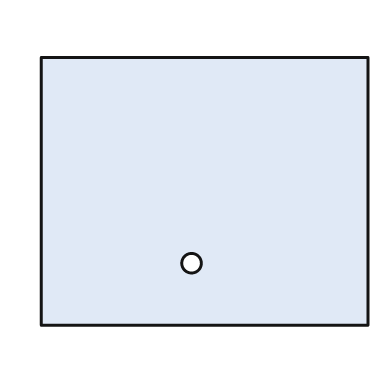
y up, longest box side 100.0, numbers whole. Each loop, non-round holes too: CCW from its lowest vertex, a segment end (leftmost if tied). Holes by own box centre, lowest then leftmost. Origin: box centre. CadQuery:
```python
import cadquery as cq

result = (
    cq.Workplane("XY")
    .moveTo(-50.0, -41.0)
    .lineTo(50.0, -41.0)
    .lineTo(50.0, 41.0)
    .lineTo(-50.0, 41.0)
    .close()
    .moveTo(-4.0, -22.0)
    .circle(3.0)
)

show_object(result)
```